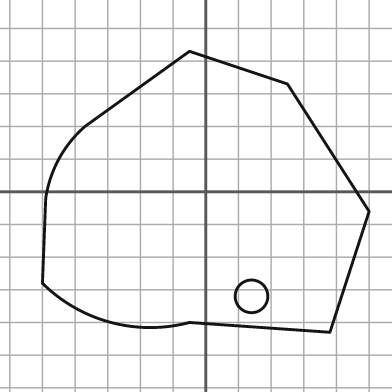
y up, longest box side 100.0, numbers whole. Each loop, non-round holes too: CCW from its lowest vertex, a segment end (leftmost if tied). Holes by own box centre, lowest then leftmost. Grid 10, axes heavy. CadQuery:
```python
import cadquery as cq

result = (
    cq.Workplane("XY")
    .moveTo(38.0, -43.0)
    .lineTo(50.0, -6.0)
    .lineTo(25.0, 33.0)
    .lineTo(-5.0, 43.0)
    .lineTo(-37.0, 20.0)
    .threePointArc((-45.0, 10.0), (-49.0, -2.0))
    .lineTo(-50.0, -28.0)
    .threePointArc((-29.0, -40.0), (-5.0, -40.0))
    .close()
    .moveTo(14.0, -32.0)
    .circle(5.0)
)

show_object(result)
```